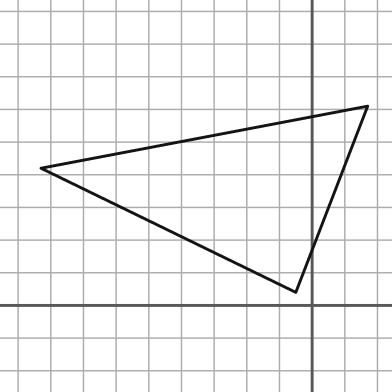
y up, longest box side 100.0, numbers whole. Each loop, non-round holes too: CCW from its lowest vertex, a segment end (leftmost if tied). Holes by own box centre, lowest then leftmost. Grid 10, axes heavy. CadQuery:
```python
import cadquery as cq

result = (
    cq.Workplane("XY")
    .moveTo(-5.0, 4.0)
    .lineTo(17.0, 61.0)
    .lineTo(-83.0, 42.0)
    .close()
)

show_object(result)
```